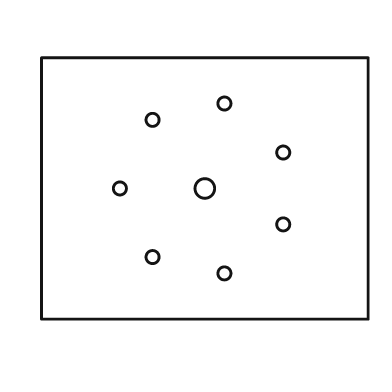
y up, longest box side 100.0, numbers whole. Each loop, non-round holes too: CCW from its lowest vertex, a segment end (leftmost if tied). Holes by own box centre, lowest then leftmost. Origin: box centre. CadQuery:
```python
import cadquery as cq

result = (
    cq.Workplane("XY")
    .moveTo(-50.0, -40.0)
    .lineTo(50.0, -40.0)
    .lineTo(50.0, 40.0)
    .lineTo(-50.0, 40.0)
    .close()
    .moveTo(6.0, -26.0)
    .circle(2.0)
    .moveTo(-16.0, -21.0)
    .circle(2.0)
    .moveTo(24.0, -11.0)
    .circle(2.0)
    .moveTo(-26.0, 0.0)
    .circle(2.0)
    .moveTo(0.0, 0.0)
    .circle(3.0)
    .moveTo(24.0, 11.0)
    .circle(2.0)
    .moveTo(-16.0, 21.0)
    .circle(2.0)
    .moveTo(6.0, 26.0)
    .circle(2.0)
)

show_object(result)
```